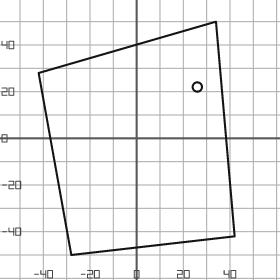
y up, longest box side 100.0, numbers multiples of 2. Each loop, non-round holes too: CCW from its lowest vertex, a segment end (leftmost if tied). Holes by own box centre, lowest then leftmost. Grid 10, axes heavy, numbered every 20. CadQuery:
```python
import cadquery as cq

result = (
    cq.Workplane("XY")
    .moveTo(-28.0, -50.0)
    .lineTo(42.0, -42.0)
    .lineTo(34.0, 50.0)
    .lineTo(-42.0, 28.0)
    .close()
    .moveTo(26.0, 22.0)
    .circle(2.0)
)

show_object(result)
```